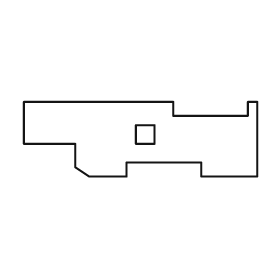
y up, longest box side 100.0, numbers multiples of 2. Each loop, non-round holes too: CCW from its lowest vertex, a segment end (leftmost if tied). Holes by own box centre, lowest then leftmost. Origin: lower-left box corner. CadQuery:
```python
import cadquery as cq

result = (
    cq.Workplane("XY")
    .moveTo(28.0, 0.0)
    .lineTo(44.0, 0.0)
    .lineTo(44.0, 6.0)
    .lineTo(76.0, 6.0)
    .lineTo(76.0, 0.0)
    .lineTo(100.0, 0.0)
    .lineTo(100.0, 32.0)
    .lineTo(96.0, 32.0)
    .lineTo(96.0, 26.0)
    .lineTo(64.0, 26.0)
    .lineTo(64.0, 32.0)
    .lineTo(0.0, 32.0)
    .lineTo(0.0, 14.0)
    .lineTo(22.0, 14.0)
    .lineTo(22.0, 4.0)
    .close()
    .moveTo(48.0, 14.0)
    .lineTo(56.0, 14.0)
    .lineTo(56.0, 22.0)
    .lineTo(48.0, 22.0)
    .close()
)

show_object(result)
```